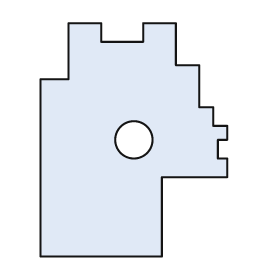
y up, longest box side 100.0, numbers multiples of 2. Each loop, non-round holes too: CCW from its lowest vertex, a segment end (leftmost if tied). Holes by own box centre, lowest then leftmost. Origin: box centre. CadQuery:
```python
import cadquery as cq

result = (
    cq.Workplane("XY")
    .moveTo(-40.0, -50.0)
    .lineTo(12.0, -50.0)
    .lineTo(12.0, -16.0)
    .lineTo(40.0, -16.0)
    .lineTo(40.0, -8.0)
    .lineTo(36.0, -8.0)
    .lineTo(36.0, 0.0)
    .lineTo(40.0, 0.0)
    .lineTo(40.0, 6.0)
    .lineTo(34.0, 6.0)
    .lineTo(34.0, 14.0)
    .lineTo(28.0, 14.0)
    .lineTo(28.0, 32.0)
    .lineTo(18.0, 32.0)
    .lineTo(18.0, 50.0)
    .lineTo(4.0, 50.0)
    .lineTo(4.0, 42.0)
    .lineTo(-14.0, 42.0)
    .lineTo(-14.0, 50.0)
    .lineTo(-28.0, 50.0)
    .lineTo(-28.0, 26.0)
    .lineTo(-40.0, 26.0)
    .close()
    .moveTo(0.0, 0.0)
    .circle(8.0)
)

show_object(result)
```